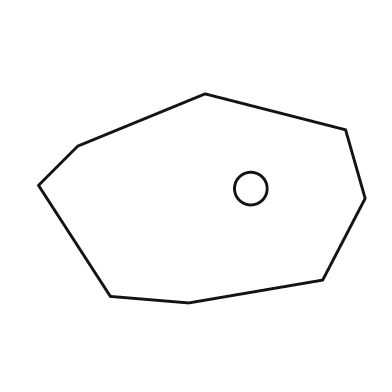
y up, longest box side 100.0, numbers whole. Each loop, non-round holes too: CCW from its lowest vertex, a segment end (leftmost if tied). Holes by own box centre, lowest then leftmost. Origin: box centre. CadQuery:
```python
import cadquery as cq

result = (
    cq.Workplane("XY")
    .moveTo(-4.0, -32.0)
    .lineTo(37.0, -25.0)
    .lineTo(50.0, 0.0)
    .lineTo(44.0, 21.0)
    .lineTo(1.0, 32.0)
    .lineTo(-38.0, 16.0)
    .lineTo(-50.0, 4.0)
    .lineTo(-28.0, -30.0)
    .close()
    .moveTo(15.0, 3.0)
    .circle(5.0)
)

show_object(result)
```